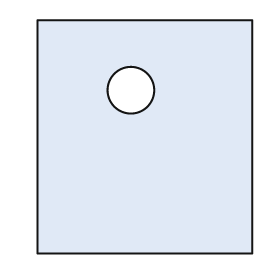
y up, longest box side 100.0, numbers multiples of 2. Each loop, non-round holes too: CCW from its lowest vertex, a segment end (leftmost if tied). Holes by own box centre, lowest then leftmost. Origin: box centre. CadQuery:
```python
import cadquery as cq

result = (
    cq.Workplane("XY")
    .moveTo(-46.0, -50.0)
    .lineTo(46.0, -50.0)
    .lineTo(46.0, 50.0)
    .lineTo(-46.0, 50.0)
    .close()
    .moveTo(-6.0, 20.0)
    .circle(10.0)
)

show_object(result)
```